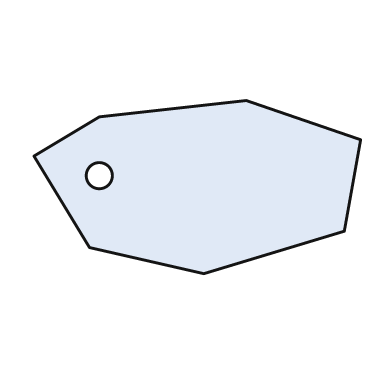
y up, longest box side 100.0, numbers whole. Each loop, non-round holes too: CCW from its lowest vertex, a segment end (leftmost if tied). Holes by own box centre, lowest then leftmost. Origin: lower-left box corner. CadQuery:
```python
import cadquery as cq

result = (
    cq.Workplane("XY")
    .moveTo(52.0, 0.0)
    .lineTo(95.0, 13.0)
    .lineTo(100.0, 41.0)
    .lineTo(65.0, 53.0)
    .lineTo(20.0, 48.0)
    .lineTo(0.0, 36.0)
    .lineTo(17.0, 8.0)
    .close()
    .moveTo(20.0, 30.0)
    .circle(4.0)
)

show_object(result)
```